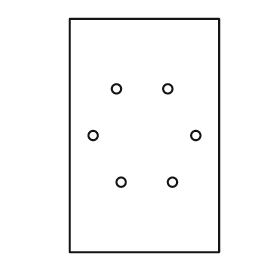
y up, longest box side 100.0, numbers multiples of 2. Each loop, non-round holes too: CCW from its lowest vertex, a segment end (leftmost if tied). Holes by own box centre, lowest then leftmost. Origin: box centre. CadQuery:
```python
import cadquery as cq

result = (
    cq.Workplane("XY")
    .moveTo(-32.0, -50.0)
    .lineTo(32.0, -50.0)
    .lineTo(32.0, 50.0)
    .lineTo(-32.0, 50.0)
    .close()
    .moveTo(-10.0, -20.0)
    .circle(2.0)
    .moveTo(12.0, -20.0)
    .circle(2.0)
    .moveTo(-22.0, 0.0)
    .circle(2.0)
    .moveTo(22.0, 0.0)
    .circle(2.0)
    .moveTo(-12.0, 20.0)
    .circle(2.0)
    .moveTo(10.0, 20.0)
    .circle(2.0)
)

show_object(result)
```